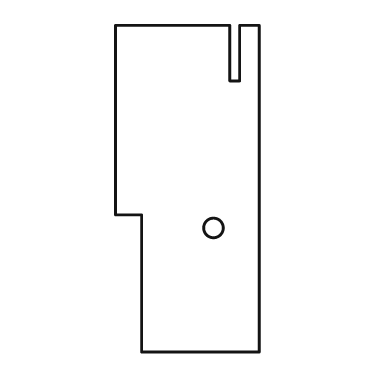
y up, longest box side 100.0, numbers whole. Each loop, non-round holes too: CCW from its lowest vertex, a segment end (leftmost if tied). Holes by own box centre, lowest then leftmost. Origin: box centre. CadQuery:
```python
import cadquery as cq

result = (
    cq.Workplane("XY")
    .moveTo(-14.0, -50.0)
    .lineTo(22.0, -50.0)
    .lineTo(22.0, 50.0)
    .lineTo(16.0, 50.0)
    .lineTo(16.0, 33.0)
    .lineTo(13.0, 33.0)
    .lineTo(13.0, 50.0)
    .lineTo(-22.0, 50.0)
    .lineTo(-22.0, -8.0)
    .lineTo(-14.0, -8.0)
    .close()
    .moveTo(8.0, -12.0)
    .circle(3.0)
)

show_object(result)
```